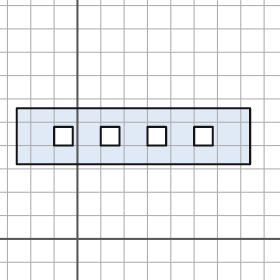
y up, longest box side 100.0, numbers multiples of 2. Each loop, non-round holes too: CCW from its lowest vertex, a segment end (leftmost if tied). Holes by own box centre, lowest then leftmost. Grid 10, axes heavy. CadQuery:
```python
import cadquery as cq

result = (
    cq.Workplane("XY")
    .moveTo(-26.0, 32.0)
    .lineTo(74.0, 32.0)
    .lineTo(74.0, 56.0)
    .lineTo(-26.0, 56.0)
    .close()
    .moveTo(-10.0, 40.0)
    .lineTo(-2.0, 40.0)
    .lineTo(-2.0, 48.0)
    .lineTo(-10.0, 48.0)
    .close()
    .moveTo(10.0, 40.0)
    .lineTo(18.0, 40.0)
    .lineTo(18.0, 48.0)
    .lineTo(10.0, 48.0)
    .close()
    .moveTo(30.0, 40.0)
    .lineTo(38.0, 40.0)
    .lineTo(38.0, 48.0)
    .lineTo(30.0, 48.0)
    .close()
    .moveTo(50.0, 40.0)
    .lineTo(58.0, 40.0)
    .lineTo(58.0, 48.0)
    .lineTo(50.0, 48.0)
    .close()
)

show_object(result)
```